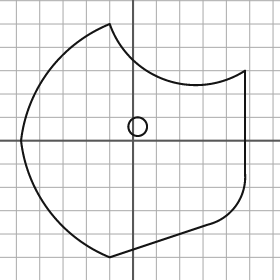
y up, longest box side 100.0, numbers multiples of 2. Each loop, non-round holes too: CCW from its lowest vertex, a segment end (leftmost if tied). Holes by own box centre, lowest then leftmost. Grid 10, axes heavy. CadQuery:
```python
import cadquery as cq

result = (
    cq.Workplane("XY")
    .moveTo(-10.0, -50.0)
    .lineTo(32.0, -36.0)
    .threePointArc((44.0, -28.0), (48.0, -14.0))
    .lineTo(48.0, 30.0)
    .threePointArc((14.0, 26.0), (-10.0, 50.0))
    .threePointArc((-36.0, 30.0), (-48.0, 0.0))
    .threePointArc((-36.0, -30.0), (-10.0, -50.0))
    .close()
    .moveTo(2.0, 6.0)
    .circle(4.0)
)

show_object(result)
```